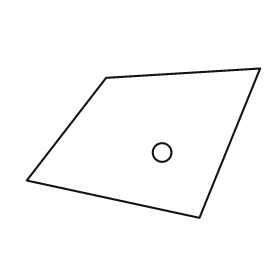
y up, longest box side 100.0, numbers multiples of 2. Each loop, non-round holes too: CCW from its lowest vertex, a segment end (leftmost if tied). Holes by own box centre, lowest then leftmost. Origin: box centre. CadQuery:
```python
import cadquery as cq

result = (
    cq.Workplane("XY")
    .moveTo(24.0, -32.0)
    .lineTo(50.0, 32.0)
    .lineTo(-16.0, 28.0)
    .lineTo(-50.0, -16.0)
    .close()
    .moveTo(8.0, -4.0)
    .circle(4.0)
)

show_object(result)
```